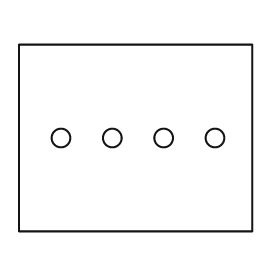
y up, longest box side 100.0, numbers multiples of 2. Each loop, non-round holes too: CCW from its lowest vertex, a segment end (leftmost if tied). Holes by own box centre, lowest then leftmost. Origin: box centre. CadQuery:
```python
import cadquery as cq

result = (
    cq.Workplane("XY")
    .moveTo(-50.0, -40.0)
    .lineTo(50.0, -40.0)
    .lineTo(50.0, 40.0)
    .lineTo(-50.0, 40.0)
    .close()
    .moveTo(-32.0, 0.0)
    .circle(4.0)
    .moveTo(-10.0, 0.0)
    .circle(4.0)
    .moveTo(12.0, 0.0)
    .circle(4.0)
    .moveTo(34.0, 0.0)
    .circle(4.0)
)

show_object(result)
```